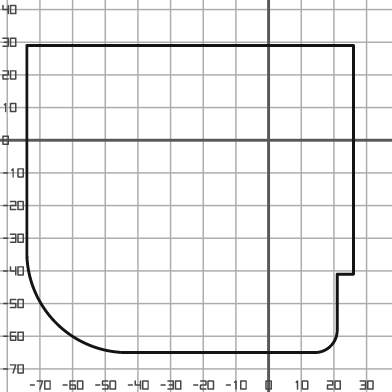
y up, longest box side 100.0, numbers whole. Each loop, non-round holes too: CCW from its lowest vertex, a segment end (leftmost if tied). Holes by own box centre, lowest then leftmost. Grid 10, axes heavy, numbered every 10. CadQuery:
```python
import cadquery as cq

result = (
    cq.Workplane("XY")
    .moveTo(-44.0, -65.0)
    .lineTo(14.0, -65.0)
    .threePointArc((19.0, -63.0), (21.0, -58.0))
    .lineTo(21.0, -41.0)
    .lineTo(26.0, -41.0)
    .lineTo(26.0, 29.0)
    .lineTo(-74.0, 29.0)
    .lineTo(-74.0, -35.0)
    .threePointArc((-65.0, -56.0), (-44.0, -65.0))
    .close()
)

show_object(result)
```